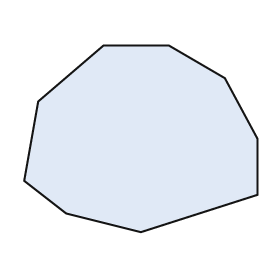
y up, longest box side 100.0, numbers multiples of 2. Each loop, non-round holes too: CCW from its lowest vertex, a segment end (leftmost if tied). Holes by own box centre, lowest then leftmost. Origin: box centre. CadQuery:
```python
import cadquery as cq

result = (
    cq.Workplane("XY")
    .moveTo(0.0, -40.0)
    .lineTo(50.0, -24.0)
    .lineTo(50.0, 0.0)
    .lineTo(36.0, 26.0)
    .lineTo(12.0, 40.0)
    .lineTo(-16.0, 40.0)
    .lineTo(-44.0, 16.0)
    .lineTo(-50.0, -18.0)
    .lineTo(-32.0, -32.0)
    .close()
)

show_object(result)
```